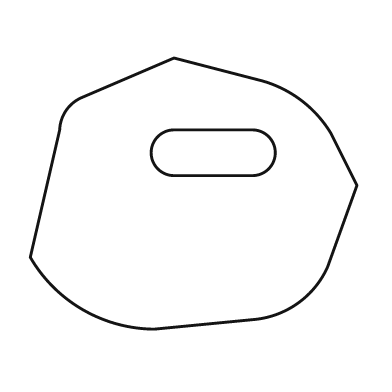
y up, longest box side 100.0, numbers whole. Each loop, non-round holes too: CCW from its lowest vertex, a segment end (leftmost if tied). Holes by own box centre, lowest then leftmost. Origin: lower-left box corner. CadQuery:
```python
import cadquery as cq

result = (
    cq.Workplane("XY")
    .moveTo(38.0, 0.0)
    .lineTo(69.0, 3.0)
    .threePointArc((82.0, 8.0), (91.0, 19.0))
    .lineTo(100.0, 44.0)
    .lineTo(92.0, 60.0)
    .threePointArc((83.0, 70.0), (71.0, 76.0))
    .lineTo(44.0, 83.0)
    .lineTo(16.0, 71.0)
    .threePointArc((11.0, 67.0), (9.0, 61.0))
    .lineTo(0.0, 22.0)
    .threePointArc((16.0, 6.0), (38.0, 0.0))
    .close()
    .moveTo(44.0, 47.0)
    .lineTo(68.0, 47.0)
    .threePointArc((75.0, 54.0), (68.0, 61.0))
    .lineTo(44.0, 61.0)
    .threePointArc((37.0, 54.0), (44.0, 47.0))
    .close()
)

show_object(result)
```